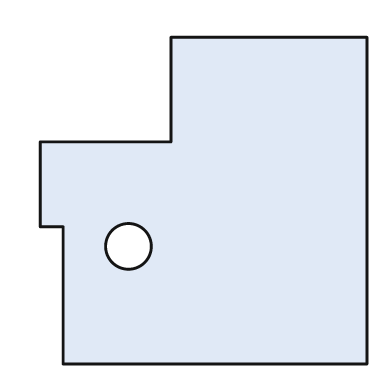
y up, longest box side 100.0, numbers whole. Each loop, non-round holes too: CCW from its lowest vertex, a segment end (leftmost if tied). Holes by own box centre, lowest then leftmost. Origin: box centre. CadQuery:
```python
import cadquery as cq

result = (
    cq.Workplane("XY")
    .moveTo(-43.0, -50.0)
    .lineTo(50.0, -50.0)
    .lineTo(50.0, 50.0)
    .lineTo(-10.0, 50.0)
    .lineTo(-10.0, 18.0)
    .lineTo(-50.0, 18.0)
    .lineTo(-50.0, -8.0)
    .lineTo(-43.0, -8.0)
    .close()
    .moveTo(-23.0, -14.0)
    .circle(7.0)
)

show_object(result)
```